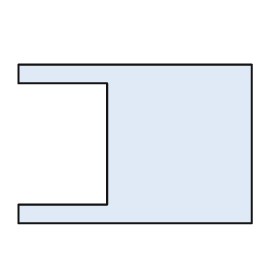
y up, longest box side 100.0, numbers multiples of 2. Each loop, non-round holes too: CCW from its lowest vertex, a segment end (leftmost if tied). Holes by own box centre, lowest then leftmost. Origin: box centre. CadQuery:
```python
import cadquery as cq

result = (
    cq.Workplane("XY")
    .moveTo(-50.0, -34.0)
    .lineTo(50.0, -34.0)
    .lineTo(50.0, 34.0)
    .lineTo(-50.0, 34.0)
    .lineTo(-50.0, 26.0)
    .lineTo(-12.0, 26.0)
    .lineTo(-12.0, -26.0)
    .lineTo(-50.0, -26.0)
    .close()
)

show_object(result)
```